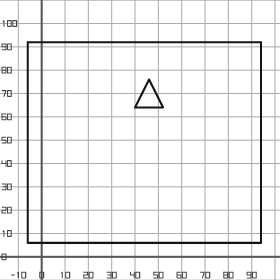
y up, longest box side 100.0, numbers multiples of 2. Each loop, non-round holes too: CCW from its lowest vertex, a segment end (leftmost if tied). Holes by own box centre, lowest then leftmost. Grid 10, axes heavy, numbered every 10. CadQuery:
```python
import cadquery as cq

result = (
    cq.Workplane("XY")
    .moveTo(-6.0, 6.0)
    .lineTo(94.0, 6.0)
    .lineTo(94.0, 92.0)
    .lineTo(-6.0, 92.0)
    .close()
    .moveTo(40.0, 64.0)
    .lineTo(52.0, 64.0)
    .lineTo(46.0, 76.0)
    .close()
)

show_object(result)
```